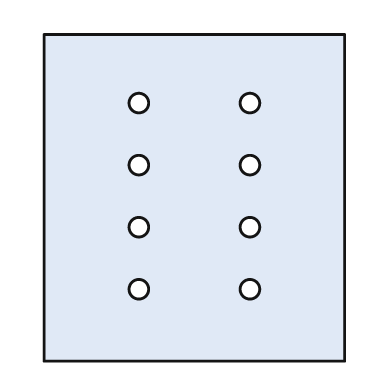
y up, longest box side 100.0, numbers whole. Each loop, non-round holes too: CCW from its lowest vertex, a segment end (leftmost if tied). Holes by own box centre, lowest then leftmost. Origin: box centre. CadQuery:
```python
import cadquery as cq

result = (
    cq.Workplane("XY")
    .moveTo(-46.0, -50.0)
    .lineTo(46.0, -50.0)
    .lineTo(46.0, 50.0)
    .lineTo(-46.0, 50.0)
    .close()
    .moveTo(-17.0, -28.0)
    .circle(3.0)
    .moveTo(17.0, -28.0)
    .circle(3.0)
    .moveTo(-17.0, -9.0)
    .circle(3.0)
    .moveTo(17.0, -9.0)
    .circle(3.0)
    .moveTo(-17.0, 10.0)
    .circle(3.0)
    .moveTo(17.0, 10.0)
    .circle(3.0)
    .moveTo(-17.0, 29.0)
    .circle(3.0)
    .moveTo(17.0, 29.0)
    .circle(3.0)
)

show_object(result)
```